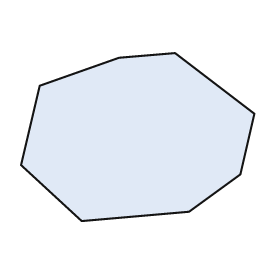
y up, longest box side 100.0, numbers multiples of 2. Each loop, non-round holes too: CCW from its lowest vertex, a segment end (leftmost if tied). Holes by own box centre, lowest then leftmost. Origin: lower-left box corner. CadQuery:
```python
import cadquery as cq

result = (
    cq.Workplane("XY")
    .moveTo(26.0, 0.0)
    .lineTo(72.0, 4.0)
    .lineTo(94.0, 20.0)
    .lineTo(100.0, 46.0)
    .lineTo(66.0, 72.0)
    .lineTo(42.0, 70.0)
    .lineTo(8.0, 58.0)
    .lineTo(0.0, 24.0)
    .close()
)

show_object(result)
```